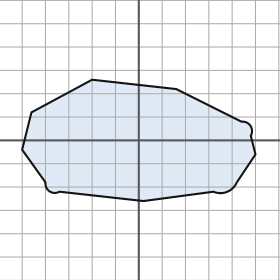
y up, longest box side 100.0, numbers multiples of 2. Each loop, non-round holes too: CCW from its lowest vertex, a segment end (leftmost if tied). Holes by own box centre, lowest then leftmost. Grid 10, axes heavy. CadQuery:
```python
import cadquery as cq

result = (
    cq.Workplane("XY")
    .moveTo(2.0, -26.0)
    .lineTo(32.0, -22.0)
    .threePointArc((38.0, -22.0), (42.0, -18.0))
    .lineTo(50.0, -6.0)
    .lineTo(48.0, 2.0)
    .threePointArc((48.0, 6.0), (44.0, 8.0))
    .lineTo(16.0, 22.0)
    .lineTo(-20.0, 26.0)
    .lineTo(-46.0, 12.0)
    .lineTo(-50.0, -4.0)
    .lineTo(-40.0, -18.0)
    .threePointArc((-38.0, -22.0), (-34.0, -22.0))
    .close()
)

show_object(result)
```